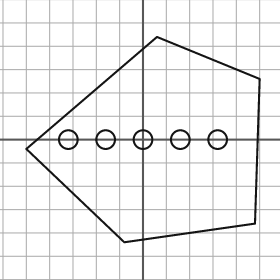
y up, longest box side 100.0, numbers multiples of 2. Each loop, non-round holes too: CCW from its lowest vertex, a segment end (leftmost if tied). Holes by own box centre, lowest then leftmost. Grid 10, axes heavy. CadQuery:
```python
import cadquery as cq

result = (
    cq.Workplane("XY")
    .moveTo(-8.0, -44.0)
    .lineTo(48.0, -36.0)
    .lineTo(50.0, 26.0)
    .lineTo(6.0, 44.0)
    .lineTo(-50.0, -4.0)
    .close()
    .moveTo(-32.0, 0.0)
    .circle(4.0)
    .moveTo(-16.0, 0.0)
    .circle(4.0)
    .moveTo(0.0, 0.0)
    .circle(4.0)
    .moveTo(16.0, 0.0)
    .circle(4.0)
    .moveTo(32.0, 0.0)
    .circle(4.0)
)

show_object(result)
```